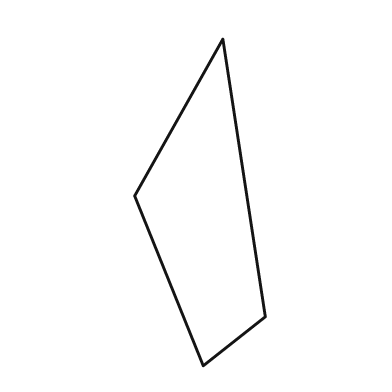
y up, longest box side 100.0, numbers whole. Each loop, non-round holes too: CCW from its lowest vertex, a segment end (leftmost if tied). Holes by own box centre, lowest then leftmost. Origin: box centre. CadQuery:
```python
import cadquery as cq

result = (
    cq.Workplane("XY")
    .moveTo(1.0, -50.0)
    .lineTo(20.0, -35.0)
    .lineTo(7.0, 50.0)
    .lineTo(-20.0, 2.0)
    .close()
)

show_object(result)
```